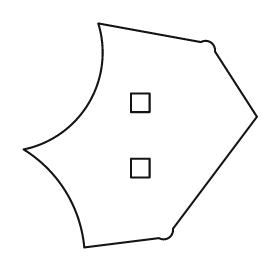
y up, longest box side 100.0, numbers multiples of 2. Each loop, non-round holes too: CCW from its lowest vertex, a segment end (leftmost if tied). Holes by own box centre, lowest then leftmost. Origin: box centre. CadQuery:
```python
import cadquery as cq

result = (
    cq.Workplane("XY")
    .moveTo(-24.0, -48.0)
    .lineTo(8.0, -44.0)
    .threePointArc((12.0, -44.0), (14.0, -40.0))
    .lineTo(50.0, 8.0)
    .lineTo(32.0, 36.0)
    .threePointArc((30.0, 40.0), (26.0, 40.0))
    .lineTo(-18.0, 48.0)
    .threePointArc((-22.0, 14.0), (-50.0, -6.0))
    .threePointArc((-32.0, -24.0), (-24.0, -48.0))
    .close()
    .moveTo(-4.0, -18.0)
    .lineTo(4.0, -18.0)
    .lineTo(4.0, -10.0)
    .lineTo(-4.0, -10.0)
    .close()
    .moveTo(-4.0, 10.0)
    .lineTo(4.0, 10.0)
    .lineTo(4.0, 18.0)
    .lineTo(-4.0, 18.0)
    .close()
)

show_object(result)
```